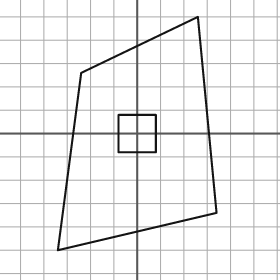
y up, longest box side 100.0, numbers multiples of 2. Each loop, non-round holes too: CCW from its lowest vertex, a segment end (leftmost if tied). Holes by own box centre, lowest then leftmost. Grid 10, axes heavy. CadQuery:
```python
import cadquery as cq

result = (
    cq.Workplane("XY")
    .moveTo(-34.0, -50.0)
    .lineTo(34.0, -34.0)
    .lineTo(26.0, 50.0)
    .lineTo(-24.0, 26.0)
    .close()
    .moveTo(-8.0, -8.0)
    .lineTo(8.0, -8.0)
    .lineTo(8.0, 8.0)
    .lineTo(-8.0, 8.0)
    .close()
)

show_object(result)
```